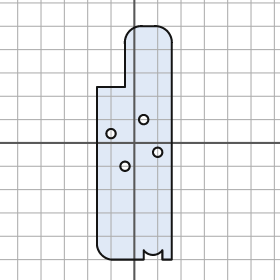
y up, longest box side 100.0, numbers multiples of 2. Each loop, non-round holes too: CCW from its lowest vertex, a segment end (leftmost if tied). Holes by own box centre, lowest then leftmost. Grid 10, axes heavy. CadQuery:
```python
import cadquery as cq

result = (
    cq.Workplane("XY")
    .moveTo(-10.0, -50.0)
    .lineTo(4.0, -50.0)
    .lineTo(4.0, -46.0)
    .threePointArc((8.0, -48.0), (12.0, -46.0))
    .lineTo(12.0, -50.0)
    .lineTo(16.0, -50.0)
    .lineTo(16.0, 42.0)
    .threePointArc((14.0, 48.0), (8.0, 50.0))
    .lineTo(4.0, 50.0)
    .threePointArc((-2.0, 48.0), (-4.0, 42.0))
    .lineTo(-4.0, 24.0)
    .lineTo(-16.0, 24.0)
    .lineTo(-16.0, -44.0)
    .threePointArc((-14.0, -48.0), (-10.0, -50.0))
    .close()
    .moveTo(-4.0, -10.0)
    .circle(2.0)
    .moveTo(10.0, -4.0)
    .circle(2.0)
    .moveTo(-10.0, 4.0)
    .circle(2.0)
    .moveTo(4.0, 10.0)
    .circle(2.0)
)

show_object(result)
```